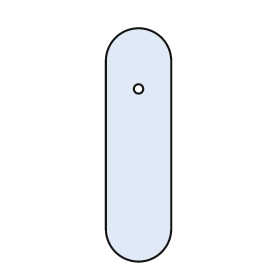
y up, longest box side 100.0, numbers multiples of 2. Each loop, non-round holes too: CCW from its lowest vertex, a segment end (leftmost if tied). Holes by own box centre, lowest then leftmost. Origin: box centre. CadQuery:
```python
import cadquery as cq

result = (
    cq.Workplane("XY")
    .moveTo(-14.0, -36.0)
    .threePointArc((0.0, -50.0), (14.0, -36.0))
    .lineTo(14.0, 36.0)
    .threePointArc((0.0, 50.0), (-14.0, 36.0))
    .close()
    .moveTo(0.0, 24.0)
    .circle(2.0)
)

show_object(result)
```